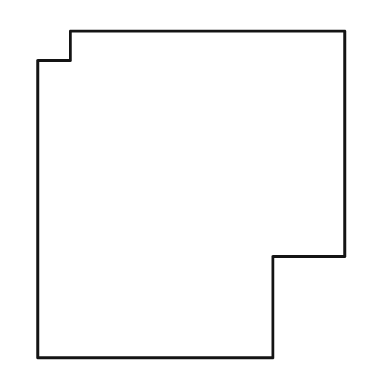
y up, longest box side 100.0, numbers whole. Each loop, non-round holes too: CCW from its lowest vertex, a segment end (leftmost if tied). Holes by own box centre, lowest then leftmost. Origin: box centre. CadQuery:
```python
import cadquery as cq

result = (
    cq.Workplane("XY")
    .moveTo(-47.0, -50.0)
    .lineTo(25.0, -50.0)
    .lineTo(25.0, -19.0)
    .lineTo(47.0, -19.0)
    .lineTo(47.0, 50.0)
    .lineTo(-37.0, 50.0)
    .lineTo(-37.0, 41.0)
    .lineTo(-47.0, 41.0)
    .close()
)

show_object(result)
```